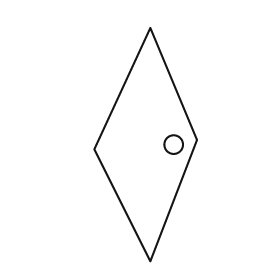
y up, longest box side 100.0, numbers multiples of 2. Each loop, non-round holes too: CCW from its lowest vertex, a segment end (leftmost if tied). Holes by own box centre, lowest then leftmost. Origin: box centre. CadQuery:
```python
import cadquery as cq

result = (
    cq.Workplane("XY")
    .moveTo(2.0, -50.0)
    .lineTo(22.0, 2.0)
    .lineTo(2.0, 50.0)
    .lineTo(-22.0, -2.0)
    .close()
    .moveTo(12.0, 0.0)
    .circle(4.0)
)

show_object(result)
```